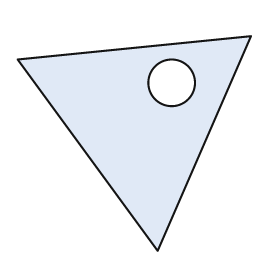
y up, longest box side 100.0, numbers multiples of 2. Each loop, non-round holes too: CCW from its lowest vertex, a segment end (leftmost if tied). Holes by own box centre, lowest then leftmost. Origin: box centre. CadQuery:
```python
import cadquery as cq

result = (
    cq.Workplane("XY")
    .moveTo(10.0, -46.0)
    .lineTo(50.0, 46.0)
    .lineTo(-50.0, 36.0)
    .close()
    .moveTo(16.0, 26.0)
    .circle(10.0)
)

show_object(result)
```